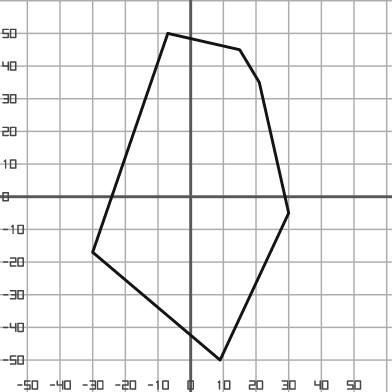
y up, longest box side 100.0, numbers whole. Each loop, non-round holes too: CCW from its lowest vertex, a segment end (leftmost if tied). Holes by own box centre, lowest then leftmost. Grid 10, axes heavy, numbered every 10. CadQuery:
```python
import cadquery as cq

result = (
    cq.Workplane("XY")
    .moveTo(9.0, -50.0)
    .lineTo(30.0, -5.0)
    .lineTo(21.0, 35.0)
    .lineTo(15.0, 45.0)
    .lineTo(-7.0, 50.0)
    .lineTo(-30.0, -17.0)
    .close()
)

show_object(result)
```